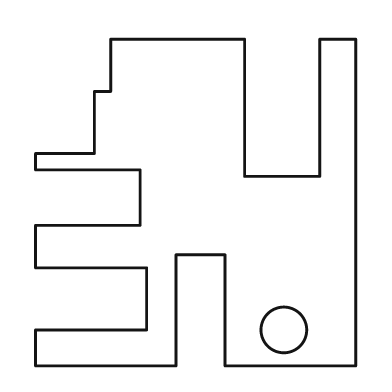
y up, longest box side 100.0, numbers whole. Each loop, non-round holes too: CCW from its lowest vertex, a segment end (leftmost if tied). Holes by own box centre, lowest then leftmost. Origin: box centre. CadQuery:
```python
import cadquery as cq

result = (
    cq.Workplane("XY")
    .moveTo(-49.0, -50.0)
    .lineTo(-6.0, -50.0)
    .lineTo(-6.0, -16.0)
    .lineTo(9.0, -16.0)
    .lineTo(9.0, -50.0)
    .lineTo(49.0, -50.0)
    .lineTo(49.0, 50.0)
    .lineTo(38.0, 50.0)
    .lineTo(38.0, 8.0)
    .lineTo(15.0, 8.0)
    .lineTo(15.0, 50.0)
    .lineTo(-26.0, 50.0)
    .lineTo(-26.0, 34.0)
    .lineTo(-31.0, 34.0)
    .lineTo(-31.0, 15.0)
    .lineTo(-49.0, 15.0)
    .lineTo(-49.0, 10.0)
    .lineTo(-17.0, 10.0)
    .lineTo(-17.0, -7.0)
    .lineTo(-49.0, -7.0)
    .lineTo(-49.0, -20.0)
    .lineTo(-15.0, -20.0)
    .lineTo(-15.0, -39.0)
    .lineTo(-49.0, -39.0)
    .close()
    .moveTo(27.0, -39.0)
    .circle(7.0)
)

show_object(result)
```